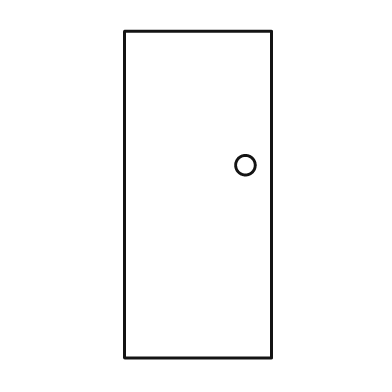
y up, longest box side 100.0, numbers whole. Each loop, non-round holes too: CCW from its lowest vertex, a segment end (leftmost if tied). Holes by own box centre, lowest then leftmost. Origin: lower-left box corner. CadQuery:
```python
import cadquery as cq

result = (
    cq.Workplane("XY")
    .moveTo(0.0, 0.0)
    .lineTo(45.0, 0.0)
    .lineTo(45.0, 100.0)
    .lineTo(0.0, 100.0)
    .close()
    .moveTo(37.0, 59.0)
    .circle(3.0)
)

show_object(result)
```